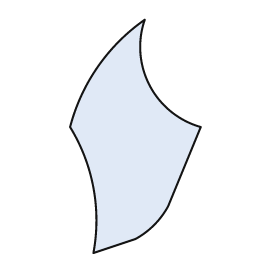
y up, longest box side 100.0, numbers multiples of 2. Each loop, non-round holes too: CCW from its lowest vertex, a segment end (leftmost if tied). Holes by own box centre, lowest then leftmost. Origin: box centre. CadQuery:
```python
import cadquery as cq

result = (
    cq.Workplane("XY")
    .moveTo(-18.0, -50.0)
    .lineTo(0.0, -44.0)
    .threePointArc((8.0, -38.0), (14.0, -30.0))
    .lineTo(28.0, 4.0)
    .threePointArc((6.0, 22.0), (4.0, 50.0))
    .threePointArc((-16.0, 30.0), (-28.0, 4.0))
    .threePointArc((-18.0, -22.0), (-18.0, -50.0))
    .close()
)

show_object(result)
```